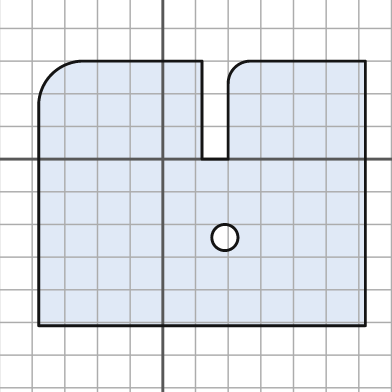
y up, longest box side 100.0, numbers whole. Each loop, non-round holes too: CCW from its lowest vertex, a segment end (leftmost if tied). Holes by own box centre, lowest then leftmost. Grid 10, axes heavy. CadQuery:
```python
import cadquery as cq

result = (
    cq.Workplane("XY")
    .moveTo(-38.0, -51.0)
    .lineTo(62.0, -51.0)
    .lineTo(62.0, 30.0)
    .lineTo(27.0, 30.0)
    .threePointArc((22.0, 28.0), (20.0, 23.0))
    .lineTo(20.0, 0.0)
    .lineTo(12.0, 0.0)
    .lineTo(12.0, 30.0)
    .lineTo(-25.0, 30.0)
    .threePointArc((-34.0, 26.0), (-38.0, 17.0))
    .close()
    .moveTo(19.0, -24.0)
    .circle(4.0)
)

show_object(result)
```